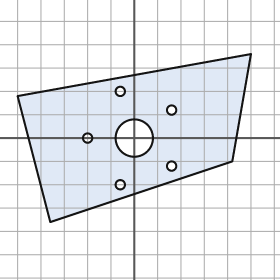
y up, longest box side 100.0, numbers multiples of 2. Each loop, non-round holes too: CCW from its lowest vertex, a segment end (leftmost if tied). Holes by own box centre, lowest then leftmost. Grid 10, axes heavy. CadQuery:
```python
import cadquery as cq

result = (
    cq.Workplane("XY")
    .moveTo(-36.0, -36.0)
    .lineTo(42.0, -10.0)
    .lineTo(50.0, 36.0)
    .lineTo(-50.0, 18.0)
    .close()
    .moveTo(-6.0, -20.0)
    .circle(2.0)
    .moveTo(16.0, -12.0)
    .circle(2.0)
    .moveTo(-20.0, 0.0)
    .circle(2.0)
    .moveTo(0.0, 0.0)
    .circle(8.0)
    .moveTo(16.0, 12.0)
    .circle(2.0)
    .moveTo(-6.0, 20.0)
    .circle(2.0)
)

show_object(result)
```